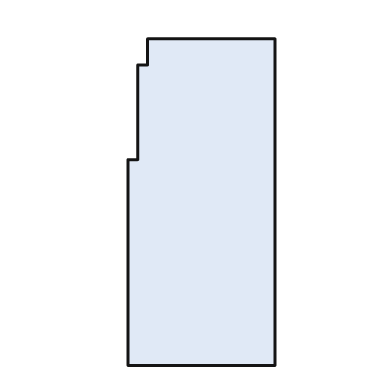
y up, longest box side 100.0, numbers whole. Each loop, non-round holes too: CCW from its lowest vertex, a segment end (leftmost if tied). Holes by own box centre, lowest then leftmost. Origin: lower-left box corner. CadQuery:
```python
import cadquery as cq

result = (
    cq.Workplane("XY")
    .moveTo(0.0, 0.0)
    .lineTo(45.0, 0.0)
    .lineTo(45.0, 100.0)
    .lineTo(6.0, 100.0)
    .lineTo(6.0, 92.0)
    .lineTo(3.0, 92.0)
    .lineTo(3.0, 63.0)
    .lineTo(0.0, 63.0)
    .close()
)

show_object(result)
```